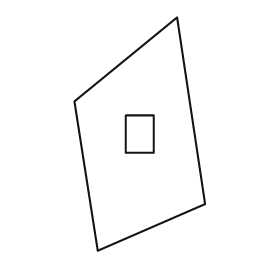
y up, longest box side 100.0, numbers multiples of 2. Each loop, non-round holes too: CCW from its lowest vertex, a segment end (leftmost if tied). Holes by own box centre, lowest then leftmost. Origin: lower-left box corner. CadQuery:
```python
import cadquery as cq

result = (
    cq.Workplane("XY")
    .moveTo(10.0, 0.0)
    .lineTo(56.0, 20.0)
    .lineTo(44.0, 100.0)
    .lineTo(0.0, 64.0)
    .close()
    .moveTo(22.0, 42.0)
    .lineTo(34.0, 42.0)
    .lineTo(34.0, 58.0)
    .lineTo(22.0, 58.0)
    .close()
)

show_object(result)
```